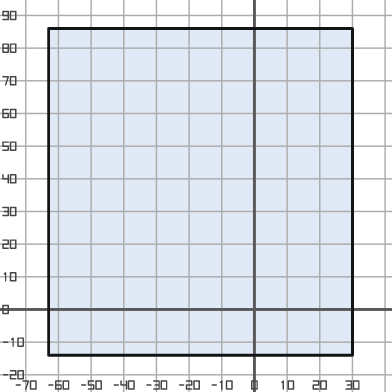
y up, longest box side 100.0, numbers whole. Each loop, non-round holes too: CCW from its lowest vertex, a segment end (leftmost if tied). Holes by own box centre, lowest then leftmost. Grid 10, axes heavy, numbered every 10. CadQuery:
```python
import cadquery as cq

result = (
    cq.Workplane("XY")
    .moveTo(-63.0, -14.0)
    .lineTo(30.0, -14.0)
    .lineTo(30.0, 86.0)
    .lineTo(-63.0, 86.0)
    .close()
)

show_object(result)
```